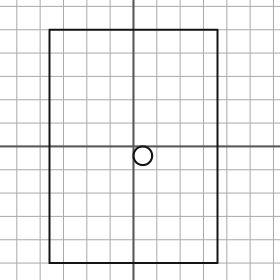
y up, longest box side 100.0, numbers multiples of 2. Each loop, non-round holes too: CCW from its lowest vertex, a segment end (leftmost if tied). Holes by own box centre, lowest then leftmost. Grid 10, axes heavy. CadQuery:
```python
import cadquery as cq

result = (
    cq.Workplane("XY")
    .moveTo(-36.0, -50.0)
    .lineTo(36.0, -50.0)
    .lineTo(36.0, 50.0)
    .lineTo(-36.0, 50.0)
    .close()
    .moveTo(4.0, -4.0)
    .circle(4.0)
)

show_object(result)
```